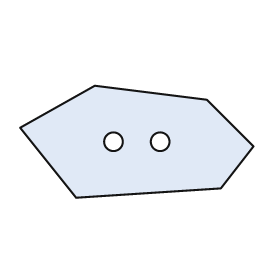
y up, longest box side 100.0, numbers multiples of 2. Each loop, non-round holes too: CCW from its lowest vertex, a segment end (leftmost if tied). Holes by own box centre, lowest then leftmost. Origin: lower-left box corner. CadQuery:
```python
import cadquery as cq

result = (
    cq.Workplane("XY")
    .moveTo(24.0, 0.0)
    .lineTo(86.0, 4.0)
    .lineTo(100.0, 22.0)
    .lineTo(80.0, 42.0)
    .lineTo(32.0, 48.0)
    .lineTo(0.0, 30.0)
    .close()
    .moveTo(40.0, 24.0)
    .circle(4.0)
    .moveTo(60.0, 24.0)
    .circle(4.0)
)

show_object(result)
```